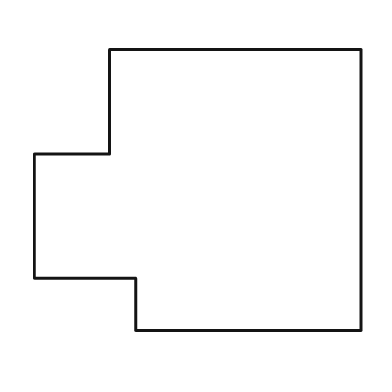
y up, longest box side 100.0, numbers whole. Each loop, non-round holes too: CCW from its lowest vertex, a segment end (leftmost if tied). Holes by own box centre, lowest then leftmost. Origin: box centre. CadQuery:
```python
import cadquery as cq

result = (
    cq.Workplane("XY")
    .moveTo(-19.0, -43.0)
    .lineTo(50.0, -43.0)
    .lineTo(50.0, 43.0)
    .lineTo(-27.0, 43.0)
    .lineTo(-27.0, 11.0)
    .lineTo(-50.0, 11.0)
    .lineTo(-50.0, -27.0)
    .lineTo(-19.0, -27.0)
    .close()
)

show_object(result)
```